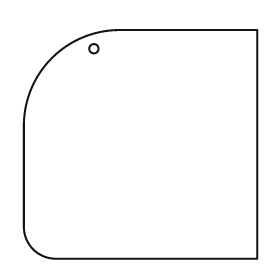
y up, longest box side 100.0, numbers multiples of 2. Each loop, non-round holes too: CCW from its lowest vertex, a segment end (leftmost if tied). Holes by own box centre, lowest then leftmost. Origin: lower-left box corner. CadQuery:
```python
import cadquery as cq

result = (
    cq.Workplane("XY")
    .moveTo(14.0, 0.0)
    .lineTo(100.0, 0.0)
    .lineTo(100.0, 98.0)
    .lineTo(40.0, 98.0)
    .threePointArc((12.0, 86.0), (0.0, 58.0))
    .lineTo(0.0, 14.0)
    .threePointArc((4.0, 4.0), (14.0, 0.0))
    .close()
    .moveTo(30.0, 90.0)
    .circle(2.0)
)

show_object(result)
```